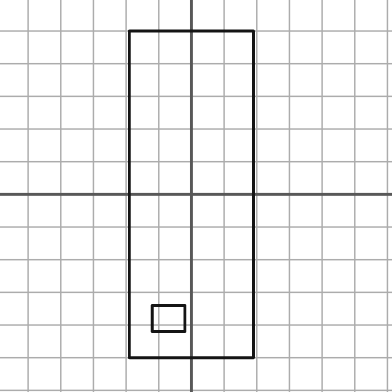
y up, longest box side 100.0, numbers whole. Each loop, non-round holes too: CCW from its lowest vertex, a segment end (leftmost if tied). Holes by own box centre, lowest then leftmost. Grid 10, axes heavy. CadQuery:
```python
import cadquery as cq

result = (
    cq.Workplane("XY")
    .moveTo(-19.0, -50.0)
    .lineTo(19.0, -50.0)
    .lineTo(19.0, 50.0)
    .lineTo(-19.0, 50.0)
    .close()
    .moveTo(-12.0, -42.0)
    .lineTo(-2.0, -42.0)
    .lineTo(-2.0, -34.0)
    .lineTo(-12.0, -34.0)
    .close()
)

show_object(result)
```